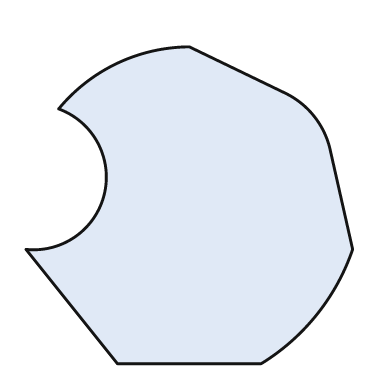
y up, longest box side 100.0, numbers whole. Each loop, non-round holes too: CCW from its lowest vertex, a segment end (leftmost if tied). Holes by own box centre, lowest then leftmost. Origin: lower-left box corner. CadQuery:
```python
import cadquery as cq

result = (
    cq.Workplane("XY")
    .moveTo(28.0, 0.0)
    .lineTo(72.0, 0.0)
    .threePointArc((89.0, 15.0), (100.0, 35.0))
    .lineTo(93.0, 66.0)
    .threePointArc((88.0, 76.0), (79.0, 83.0))
    .lineTo(50.0, 97.0)
    .threePointArc((28.0, 92.0), (10.0, 78.0))
    .threePointArc((24.0, 52.0), (0.0, 35.0))
    .close()
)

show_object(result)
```